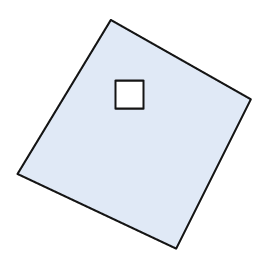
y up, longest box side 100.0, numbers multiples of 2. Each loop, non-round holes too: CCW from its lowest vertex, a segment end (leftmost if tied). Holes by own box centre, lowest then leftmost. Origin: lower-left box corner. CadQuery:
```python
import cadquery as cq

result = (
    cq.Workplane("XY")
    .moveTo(68.0, 0.0)
    .lineTo(100.0, 64.0)
    .lineTo(40.0, 98.0)
    .lineTo(0.0, 32.0)
    .close()
    .moveTo(42.0, 60.0)
    .lineTo(54.0, 60.0)
    .lineTo(54.0, 72.0)
    .lineTo(42.0, 72.0)
    .close()
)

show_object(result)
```